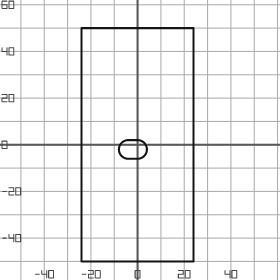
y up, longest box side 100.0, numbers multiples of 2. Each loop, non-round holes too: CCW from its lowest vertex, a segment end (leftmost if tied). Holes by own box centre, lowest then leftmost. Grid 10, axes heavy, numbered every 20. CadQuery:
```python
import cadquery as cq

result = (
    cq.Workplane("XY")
    .moveTo(-24.0, -50.0)
    .lineTo(24.0, -50.0)
    .lineTo(24.0, 50.0)
    .lineTo(-24.0, 50.0)
    .close()
    .moveTo(-4.0, -6.0)
    .lineTo(0.0, -6.0)
    .threePointArc((4.0, -2.0), (0.0, 2.0))
    .lineTo(-4.0, 2.0)
    .threePointArc((-8.0, -2.0), (-4.0, -6.0))
    .close()
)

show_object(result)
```